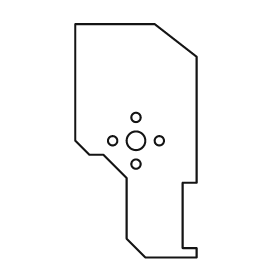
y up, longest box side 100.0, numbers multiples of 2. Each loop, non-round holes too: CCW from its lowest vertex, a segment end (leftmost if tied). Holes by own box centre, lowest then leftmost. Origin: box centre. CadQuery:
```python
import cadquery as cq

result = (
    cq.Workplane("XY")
    .moveTo(4.0, -50.0)
    .lineTo(26.0, -50.0)
    .lineTo(26.0, -46.0)
    .lineTo(20.0, -46.0)
    .lineTo(20.0, -18.0)
    .lineTo(26.0, -18.0)
    .lineTo(26.0, 36.0)
    .lineTo(8.0, 50.0)
    .lineTo(-26.0, 50.0)
    .lineTo(-26.0, 0.0)
    .lineTo(-20.0, -6.0)
    .lineTo(-14.0, -6.0)
    .lineTo(-4.0, -16.0)
    .lineTo(-4.0, -42.0)
    .close()
    .moveTo(0.0, -10.0)
    .circle(2.0)
    .moveTo(-10.0, 0.0)
    .circle(2.0)
    .moveTo(0.0, 0.0)
    .circle(4.0)
    .moveTo(10.0, 0.0)
    .circle(2.0)
    .moveTo(0.0, 10.0)
    .circle(2.0)
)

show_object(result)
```